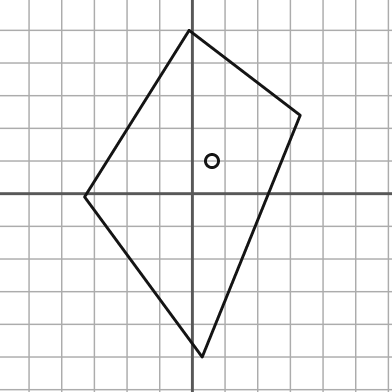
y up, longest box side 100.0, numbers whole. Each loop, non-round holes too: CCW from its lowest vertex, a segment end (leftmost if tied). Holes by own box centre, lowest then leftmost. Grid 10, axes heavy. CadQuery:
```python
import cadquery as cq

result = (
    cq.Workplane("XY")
    .moveTo(3.0, -50.0)
    .lineTo(33.0, 24.0)
    .lineTo(-1.0, 50.0)
    .lineTo(-33.0, -1.0)
    .close()
    .moveTo(6.0, 10.0)
    .circle(2.0)
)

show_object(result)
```